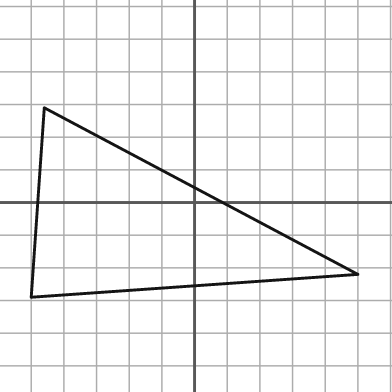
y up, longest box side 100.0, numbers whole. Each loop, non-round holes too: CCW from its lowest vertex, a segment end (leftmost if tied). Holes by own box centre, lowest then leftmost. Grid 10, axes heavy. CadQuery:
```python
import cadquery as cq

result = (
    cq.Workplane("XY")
    .moveTo(-50.0, -29.0)
    .lineTo(50.0, -22.0)
    .lineTo(-46.0, 29.0)
    .close()
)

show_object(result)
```